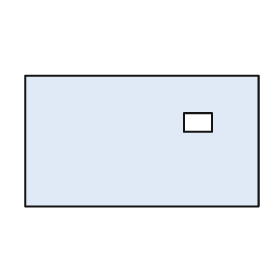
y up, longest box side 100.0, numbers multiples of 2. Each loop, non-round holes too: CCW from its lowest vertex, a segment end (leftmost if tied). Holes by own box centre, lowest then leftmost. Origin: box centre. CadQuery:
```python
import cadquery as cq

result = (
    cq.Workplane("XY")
    .moveTo(-50.0, -28.0)
    .lineTo(50.0, -28.0)
    .lineTo(50.0, 28.0)
    .lineTo(-50.0, 28.0)
    .close()
    .moveTo(18.0, 4.0)
    .lineTo(30.0, 4.0)
    .lineTo(30.0, 12.0)
    .lineTo(18.0, 12.0)
    .close()
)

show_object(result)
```